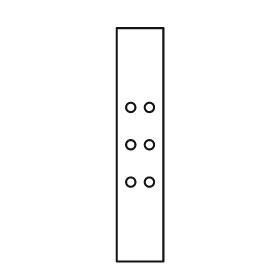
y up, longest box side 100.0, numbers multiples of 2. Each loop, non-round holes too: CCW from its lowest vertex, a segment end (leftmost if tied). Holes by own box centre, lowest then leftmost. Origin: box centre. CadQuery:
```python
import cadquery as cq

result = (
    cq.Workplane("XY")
    .moveTo(-10.0, -50.0)
    .lineTo(10.0, -50.0)
    .lineTo(10.0, 50.0)
    .lineTo(-10.0, 50.0)
    .close()
    .moveTo(-4.0, -16.0)
    .circle(2.0)
    .moveTo(4.0, -16.0)
    .circle(2.0)
    .moveTo(-4.0, 0.0)
    .circle(2.0)
    .moveTo(4.0, 0.0)
    .circle(2.0)
    .moveTo(-4.0, 16.0)
    .circle(2.0)
    .moveTo(4.0, 16.0)
    .circle(2.0)
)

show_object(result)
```